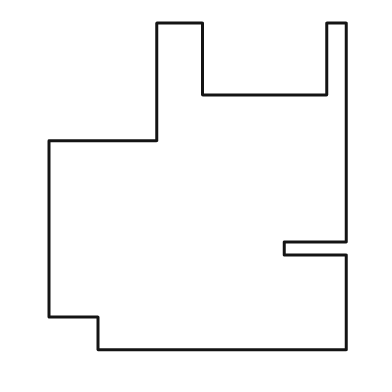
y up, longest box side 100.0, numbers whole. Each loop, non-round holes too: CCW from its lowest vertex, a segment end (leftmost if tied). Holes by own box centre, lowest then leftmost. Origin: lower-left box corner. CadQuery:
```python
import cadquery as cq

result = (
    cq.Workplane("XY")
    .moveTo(15.0, 0.0)
    .lineTo(91.0, 0.0)
    .lineTo(91.0, 29.0)
    .lineTo(72.0, 29.0)
    .lineTo(72.0, 33.0)
    .lineTo(91.0, 33.0)
    .lineTo(91.0, 100.0)
    .lineTo(85.0, 100.0)
    .lineTo(85.0, 78.0)
    .lineTo(47.0, 78.0)
    .lineTo(47.0, 100.0)
    .lineTo(33.0, 100.0)
    .lineTo(33.0, 64.0)
    .lineTo(0.0, 64.0)
    .lineTo(0.0, 10.0)
    .lineTo(15.0, 10.0)
    .close()
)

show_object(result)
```